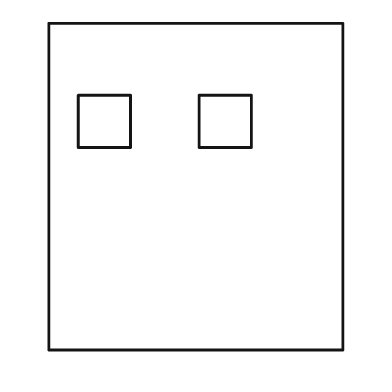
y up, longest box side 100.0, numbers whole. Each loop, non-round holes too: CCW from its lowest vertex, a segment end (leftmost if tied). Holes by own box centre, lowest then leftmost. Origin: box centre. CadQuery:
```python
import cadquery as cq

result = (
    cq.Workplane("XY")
    .moveTo(-45.0, -50.0)
    .lineTo(45.0, -50.0)
    .lineTo(45.0, 50.0)
    .lineTo(-45.0, 50.0)
    .close()
    .moveTo(-36.0, 12.0)
    .lineTo(-20.0, 12.0)
    .lineTo(-20.0, 28.0)
    .lineTo(-36.0, 28.0)
    .close()
    .moveTo(1.0, 12.0)
    .lineTo(17.0, 12.0)
    .lineTo(17.0, 28.0)
    .lineTo(1.0, 28.0)
    .close()
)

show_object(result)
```